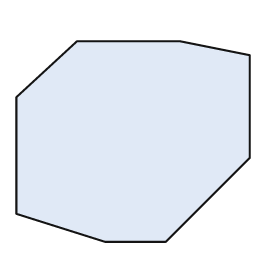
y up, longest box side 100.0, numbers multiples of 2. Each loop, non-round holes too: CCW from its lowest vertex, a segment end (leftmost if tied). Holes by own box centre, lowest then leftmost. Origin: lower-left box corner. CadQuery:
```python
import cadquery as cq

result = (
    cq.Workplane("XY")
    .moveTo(38.0, 0.0)
    .lineTo(64.0, 0.0)
    .lineTo(100.0, 36.0)
    .lineTo(100.0, 80.0)
    .lineTo(70.0, 86.0)
    .lineTo(26.0, 86.0)
    .lineTo(0.0, 62.0)
    .lineTo(0.0, 12.0)
    .close()
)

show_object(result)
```